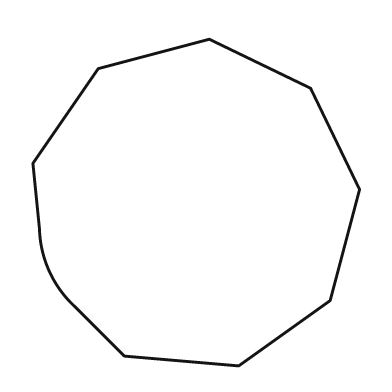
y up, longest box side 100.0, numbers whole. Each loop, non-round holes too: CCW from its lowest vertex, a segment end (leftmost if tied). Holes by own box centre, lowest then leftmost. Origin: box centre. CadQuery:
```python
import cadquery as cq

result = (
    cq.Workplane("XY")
    .moveTo(13.0, -50.0)
    .lineTo(41.0, -30.0)
    .lineTo(50.0, 4.0)
    .lineTo(35.0, 35.0)
    .lineTo(4.0, 50.0)
    .lineTo(-30.0, 41.0)
    .lineTo(-50.0, 12.0)
    .lineTo(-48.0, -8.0)
    .threePointArc((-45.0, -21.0), (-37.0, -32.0))
    .lineTo(-22.0, -47.0)
    .close()
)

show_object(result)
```